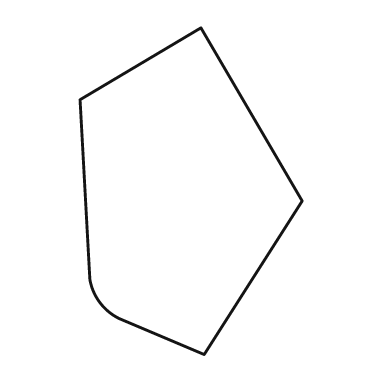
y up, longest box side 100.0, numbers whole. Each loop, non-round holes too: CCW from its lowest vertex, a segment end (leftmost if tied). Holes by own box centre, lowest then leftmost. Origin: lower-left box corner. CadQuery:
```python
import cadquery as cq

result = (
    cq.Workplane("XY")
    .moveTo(38.0, 0.0)
    .lineTo(68.0, 47.0)
    .lineTo(37.0, 100.0)
    .lineTo(0.0, 78.0)
    .lineTo(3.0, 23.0)
    .threePointArc((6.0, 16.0), (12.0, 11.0))
    .close()
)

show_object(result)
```